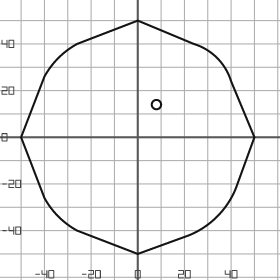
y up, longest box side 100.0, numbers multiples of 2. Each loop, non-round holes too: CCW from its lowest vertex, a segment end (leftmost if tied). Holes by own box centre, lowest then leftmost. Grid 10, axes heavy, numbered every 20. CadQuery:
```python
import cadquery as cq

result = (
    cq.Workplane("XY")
    .moveTo(0.0, -50.0)
    .lineTo(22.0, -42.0)
    .threePointArc((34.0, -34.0), (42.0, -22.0))
    .lineTo(50.0, 0.0)
    .lineTo(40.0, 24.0)
    .threePointArc((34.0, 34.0), (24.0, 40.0))
    .lineTo(0.0, 50.0)
    .lineTo(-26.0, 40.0)
    .threePointArc((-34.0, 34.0), (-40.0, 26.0))
    .lineTo(-50.0, 0.0)
    .lineTo(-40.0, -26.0)
    .threePointArc((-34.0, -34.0), (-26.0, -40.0))
    .close()
    .moveTo(8.0, 14.0)
    .circle(2.0)
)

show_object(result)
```